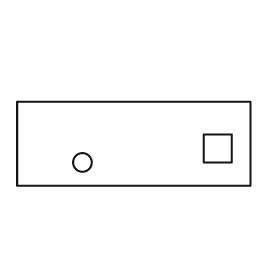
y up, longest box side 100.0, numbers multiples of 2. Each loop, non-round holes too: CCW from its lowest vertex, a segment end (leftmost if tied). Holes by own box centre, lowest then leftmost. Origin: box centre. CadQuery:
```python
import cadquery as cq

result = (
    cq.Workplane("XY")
    .moveTo(-50.0, -18.0)
    .lineTo(50.0, -18.0)
    .lineTo(50.0, 18.0)
    .lineTo(-50.0, 18.0)
    .close()
    .moveTo(-22.0, -8.0)
    .circle(4.0)
    .moveTo(30.0, -8.0)
    .lineTo(42.0, -8.0)
    .lineTo(42.0, 4.0)
    .lineTo(30.0, 4.0)
    .close()
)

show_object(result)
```